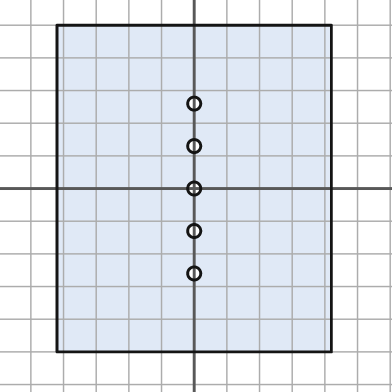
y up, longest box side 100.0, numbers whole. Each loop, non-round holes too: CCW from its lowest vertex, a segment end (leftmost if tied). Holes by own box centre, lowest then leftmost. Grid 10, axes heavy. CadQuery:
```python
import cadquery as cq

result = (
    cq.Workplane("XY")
    .moveTo(-42.0, -50.0)
    .lineTo(42.0, -50.0)
    .lineTo(42.0, 50.0)
    .lineTo(-42.0, 50.0)
    .close()
    .moveTo(0.0, -26.0)
    .circle(2.0)
    .moveTo(0.0, -13.0)
    .circle(2.0)
    .moveTo(0.0, 0.0)
    .circle(2.0)
    .moveTo(0.0, 13.0)
    .circle(2.0)
    .moveTo(0.0, 26.0)
    .circle(2.0)
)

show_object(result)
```